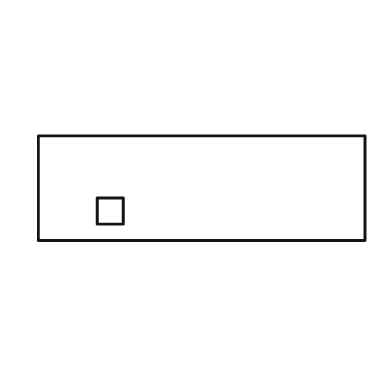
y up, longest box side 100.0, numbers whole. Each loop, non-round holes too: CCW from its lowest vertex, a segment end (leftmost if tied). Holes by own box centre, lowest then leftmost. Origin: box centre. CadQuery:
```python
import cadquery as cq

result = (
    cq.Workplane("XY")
    .moveTo(-50.0, -16.0)
    .lineTo(50.0, -16.0)
    .lineTo(50.0, 16.0)
    .lineTo(-50.0, 16.0)
    .close()
    .moveTo(-32.0, -11.0)
    .lineTo(-24.0, -11.0)
    .lineTo(-24.0, -3.0)
    .lineTo(-32.0, -3.0)
    .close()
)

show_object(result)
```